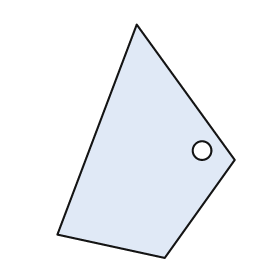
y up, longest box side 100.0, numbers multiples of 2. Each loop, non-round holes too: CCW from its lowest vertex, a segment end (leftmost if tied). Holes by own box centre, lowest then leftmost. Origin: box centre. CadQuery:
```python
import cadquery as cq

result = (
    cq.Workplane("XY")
    .moveTo(8.0, -50.0)
    .lineTo(38.0, -8.0)
    .lineTo(-4.0, 50.0)
    .lineTo(-38.0, -40.0)
    .close()
    .moveTo(24.0, -4.0)
    .circle(4.0)
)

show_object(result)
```